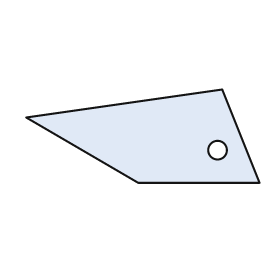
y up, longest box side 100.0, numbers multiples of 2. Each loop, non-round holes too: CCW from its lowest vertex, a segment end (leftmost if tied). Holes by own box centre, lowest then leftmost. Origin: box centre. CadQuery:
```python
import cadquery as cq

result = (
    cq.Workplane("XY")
    .moveTo(-2.0, -20.0)
    .lineTo(50.0, -20.0)
    .lineTo(34.0, 20.0)
    .lineTo(-50.0, 8.0)
    .close()
    .moveTo(32.0, -6.0)
    .circle(4.0)
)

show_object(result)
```